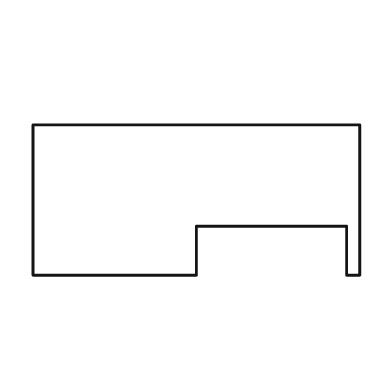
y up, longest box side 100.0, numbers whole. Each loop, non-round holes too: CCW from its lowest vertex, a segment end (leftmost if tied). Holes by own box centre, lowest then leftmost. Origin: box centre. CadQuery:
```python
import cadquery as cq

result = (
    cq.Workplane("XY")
    .moveTo(-50.0, -23.0)
    .lineTo(0.0, -23.0)
    .lineTo(0.0, -8.0)
    .lineTo(46.0, -8.0)
    .lineTo(46.0, -23.0)
    .lineTo(50.0, -23.0)
    .lineTo(50.0, 23.0)
    .lineTo(-50.0, 23.0)
    .close()
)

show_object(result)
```